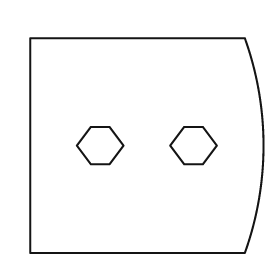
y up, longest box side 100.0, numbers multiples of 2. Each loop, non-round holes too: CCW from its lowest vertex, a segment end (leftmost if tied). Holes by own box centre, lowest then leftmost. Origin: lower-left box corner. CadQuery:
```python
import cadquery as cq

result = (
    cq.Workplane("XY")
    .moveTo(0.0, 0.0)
    .lineTo(92.0, 0.0)
    .threePointArc((100.0, 46.0), (92.0, 92.0))
    .lineTo(0.0, 92.0)
    .close()
    .moveTo(26.0, 38.0)
    .lineTo(34.0, 38.0)
    .lineTo(40.0, 46.0)
    .lineTo(34.0, 54.0)
    .lineTo(26.0, 54.0)
    .lineTo(20.0, 46.0)
    .close()
    .moveTo(66.0, 38.0)
    .lineTo(74.0, 38.0)
    .lineTo(80.0, 46.0)
    .lineTo(74.0, 54.0)
    .lineTo(66.0, 54.0)
    .lineTo(60.0, 46.0)
    .close()
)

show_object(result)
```